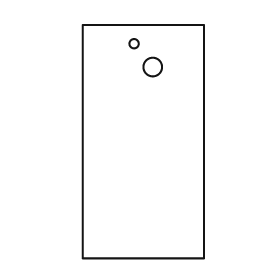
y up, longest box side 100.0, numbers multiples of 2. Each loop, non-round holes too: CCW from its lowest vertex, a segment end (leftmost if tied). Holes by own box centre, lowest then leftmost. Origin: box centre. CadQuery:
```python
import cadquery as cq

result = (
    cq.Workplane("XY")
    .moveTo(-26.0, -50.0)
    .lineTo(26.0, -50.0)
    .lineTo(26.0, 50.0)
    .lineTo(-26.0, 50.0)
    .close()
    .moveTo(4.0, 32.0)
    .circle(4.0)
    .moveTo(-4.0, 42.0)
    .circle(2.0)
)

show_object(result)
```